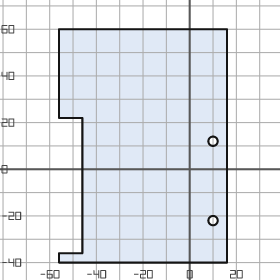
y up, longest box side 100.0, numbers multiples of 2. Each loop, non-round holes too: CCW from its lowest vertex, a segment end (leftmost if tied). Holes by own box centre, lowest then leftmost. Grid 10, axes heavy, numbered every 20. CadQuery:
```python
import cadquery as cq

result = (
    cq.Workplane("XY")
    .moveTo(-56.0, -40.0)
    .lineTo(16.0, -40.0)
    .lineTo(16.0, 60.0)
    .lineTo(-56.0, 60.0)
    .lineTo(-56.0, 22.0)
    .lineTo(-46.0, 22.0)
    .lineTo(-46.0, -36.0)
    .lineTo(-56.0, -36.0)
    .close()
    .moveTo(10.0, -22.0)
    .circle(2.0)
    .moveTo(10.0, 12.0)
    .circle(2.0)
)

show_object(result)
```